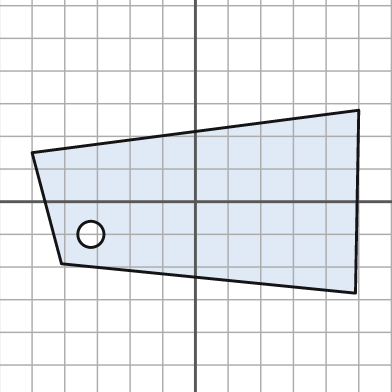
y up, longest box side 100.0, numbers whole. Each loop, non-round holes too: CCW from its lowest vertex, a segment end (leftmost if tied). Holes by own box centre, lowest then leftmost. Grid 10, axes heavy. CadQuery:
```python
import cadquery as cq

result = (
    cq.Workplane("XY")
    .moveTo(49.0, -28.0)
    .lineTo(50.0, 28.0)
    .lineTo(-50.0, 15.0)
    .lineTo(-41.0, -19.0)
    .close()
    .moveTo(-32.0, -10.0)
    .circle(4.0)
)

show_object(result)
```